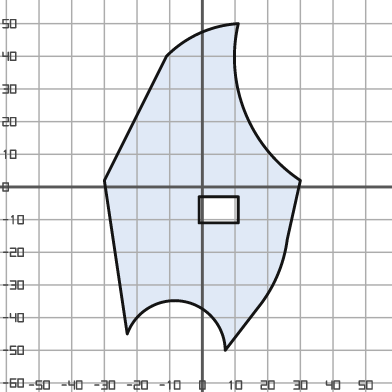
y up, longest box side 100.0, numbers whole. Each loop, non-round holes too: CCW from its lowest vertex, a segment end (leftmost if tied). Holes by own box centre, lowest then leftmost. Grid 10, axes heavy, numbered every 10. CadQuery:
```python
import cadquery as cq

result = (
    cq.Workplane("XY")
    .moveTo(7.0, -50.0)
    .lineTo(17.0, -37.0)
    .threePointArc((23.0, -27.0), (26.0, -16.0))
    .lineTo(30.0, 2.0)
    .threePointArc((13.0, 23.0), (11.0, 50.0))
    .threePointArc((-1.0, 47.0), (-11.0, 40.0))
    .lineTo(-30.0, 2.0)
    .lineTo(-23.0, -45.0)
    .threePointArc((-6.0, -35.0), (7.0, -50.0))
    .close()
    .moveTo(-1.0, -11.0)
    .lineTo(11.0, -11.0)
    .lineTo(11.0, -3.0)
    .lineTo(-1.0, -3.0)
    .close()
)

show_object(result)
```